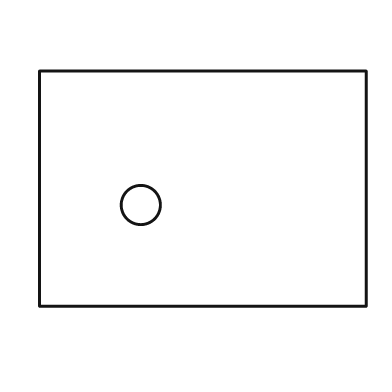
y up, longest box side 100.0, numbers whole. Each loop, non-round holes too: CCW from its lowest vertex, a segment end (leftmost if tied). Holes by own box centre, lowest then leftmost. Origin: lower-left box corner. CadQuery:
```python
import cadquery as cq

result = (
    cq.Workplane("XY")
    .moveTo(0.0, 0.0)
    .lineTo(100.0, 0.0)
    .lineTo(100.0, 72.0)
    .lineTo(0.0, 72.0)
    .close()
    .moveTo(31.0, 31.0)
    .circle(6.0)
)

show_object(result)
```